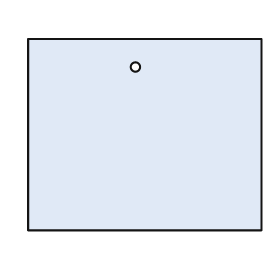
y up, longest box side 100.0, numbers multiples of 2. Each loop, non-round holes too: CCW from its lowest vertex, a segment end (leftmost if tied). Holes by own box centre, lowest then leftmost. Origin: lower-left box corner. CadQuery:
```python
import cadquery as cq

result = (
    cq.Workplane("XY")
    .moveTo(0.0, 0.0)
    .lineTo(100.0, 0.0)
    .lineTo(100.0, 82.0)
    .lineTo(0.0, 82.0)
    .close()
    .moveTo(46.0, 70.0)
    .circle(2.0)
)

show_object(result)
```